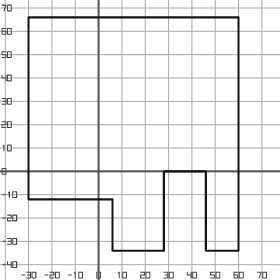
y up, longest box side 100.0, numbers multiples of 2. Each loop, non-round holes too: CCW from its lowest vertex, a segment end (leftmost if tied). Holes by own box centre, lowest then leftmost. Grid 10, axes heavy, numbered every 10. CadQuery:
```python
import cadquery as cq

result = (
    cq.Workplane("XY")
    .moveTo(6.0, -34.0)
    .lineTo(28.0, -34.0)
    .lineTo(28.0, 0.0)
    .lineTo(46.0, 0.0)
    .lineTo(46.0, -34.0)
    .lineTo(60.0, -34.0)
    .lineTo(60.0, 66.0)
    .lineTo(-30.0, 66.0)
    .lineTo(-30.0, -12.0)
    .lineTo(6.0, -12.0)
    .close()
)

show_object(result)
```